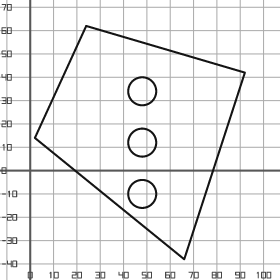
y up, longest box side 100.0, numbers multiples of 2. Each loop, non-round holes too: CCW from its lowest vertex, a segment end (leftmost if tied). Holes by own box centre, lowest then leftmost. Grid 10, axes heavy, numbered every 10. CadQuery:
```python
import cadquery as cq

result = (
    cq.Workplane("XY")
    .moveTo(66.0, -38.0)
    .lineTo(92.0, 42.0)
    .lineTo(24.0, 62.0)
    .lineTo(2.0, 14.0)
    .close()
    .moveTo(48.0, -10.0)
    .circle(6.0)
    .moveTo(48.0, 12.0)
    .circle(6.0)
    .moveTo(48.0, 34.0)
    .circle(6.0)
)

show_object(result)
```